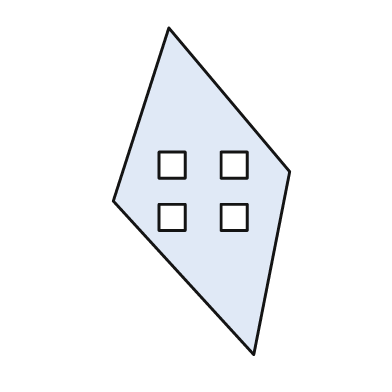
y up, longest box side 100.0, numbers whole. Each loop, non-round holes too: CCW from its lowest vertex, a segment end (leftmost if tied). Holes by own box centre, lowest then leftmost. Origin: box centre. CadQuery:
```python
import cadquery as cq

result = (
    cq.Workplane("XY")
    .moveTo(16.0, -50.0)
    .lineTo(27.0, 6.0)
    .lineTo(-10.0, 50.0)
    .lineTo(-27.0, -3.0)
    .close()
    .moveTo(-13.0, -12.0)
    .lineTo(-5.0, -12.0)
    .lineTo(-5.0, -4.0)
    .lineTo(-13.0, -4.0)
    .close()
    .moveTo(6.0, -12.0)
    .lineTo(14.0, -12.0)
    .lineTo(14.0, -4.0)
    .lineTo(6.0, -4.0)
    .close()
    .moveTo(-13.0, 4.0)
    .lineTo(-5.0, 4.0)
    .lineTo(-5.0, 12.0)
    .lineTo(-13.0, 12.0)
    .close()
    .moveTo(6.0, 4.0)
    .lineTo(14.0, 4.0)
    .lineTo(14.0, 12.0)
    .lineTo(6.0, 12.0)
    .close()
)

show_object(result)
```